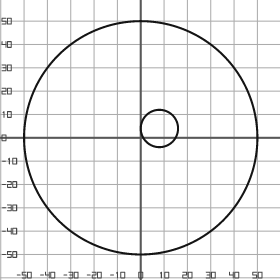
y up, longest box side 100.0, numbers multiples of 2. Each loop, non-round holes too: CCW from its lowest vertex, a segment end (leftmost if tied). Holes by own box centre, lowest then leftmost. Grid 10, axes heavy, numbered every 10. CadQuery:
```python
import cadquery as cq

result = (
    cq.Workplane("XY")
    .moveTo(0.0, 0.0)
    .circle(50.0)
    .moveTo(8.0, 4.0)
    .circle(8.0)
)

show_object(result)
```